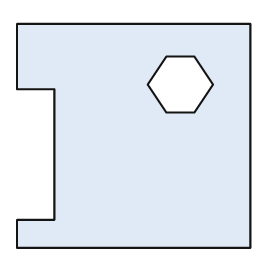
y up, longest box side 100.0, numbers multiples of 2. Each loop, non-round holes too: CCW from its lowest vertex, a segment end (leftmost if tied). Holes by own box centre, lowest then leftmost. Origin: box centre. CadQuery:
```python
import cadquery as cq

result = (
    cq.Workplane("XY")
    .moveTo(-50.0, -48.0)
    .lineTo(50.0, -48.0)
    .lineTo(50.0, 48.0)
    .lineTo(-50.0, 48.0)
    .lineTo(-50.0, 20.0)
    .lineTo(-34.0, 20.0)
    .lineTo(-34.0, -36.0)
    .lineTo(-50.0, -36.0)
    .close()
    .moveTo(14.0, 10.0)
    .lineTo(26.0, 10.0)
    .lineTo(34.0, 22.0)
    .lineTo(26.0, 34.0)
    .lineTo(14.0, 34.0)
    .lineTo(6.0, 22.0)
    .close()
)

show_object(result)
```